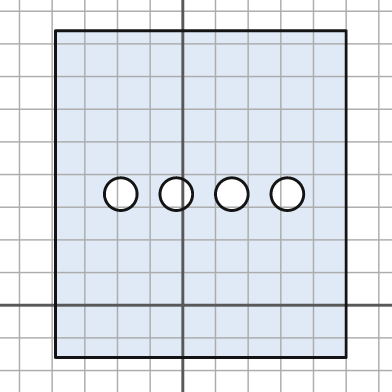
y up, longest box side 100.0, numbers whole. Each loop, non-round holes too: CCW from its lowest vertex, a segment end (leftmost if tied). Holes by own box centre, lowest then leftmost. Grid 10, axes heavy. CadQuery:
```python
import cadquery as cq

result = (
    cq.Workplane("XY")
    .moveTo(-39.0, -16.0)
    .lineTo(50.0, -16.0)
    .lineTo(50.0, 84.0)
    .lineTo(-39.0, 84.0)
    .close()
    .moveTo(-19.0, 34.0)
    .circle(5.0)
    .moveTo(-2.0, 34.0)
    .circle(5.0)
    .moveTo(15.0, 34.0)
    .circle(5.0)
    .moveTo(32.0, 34.0)
    .circle(5.0)
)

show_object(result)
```